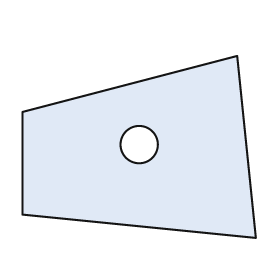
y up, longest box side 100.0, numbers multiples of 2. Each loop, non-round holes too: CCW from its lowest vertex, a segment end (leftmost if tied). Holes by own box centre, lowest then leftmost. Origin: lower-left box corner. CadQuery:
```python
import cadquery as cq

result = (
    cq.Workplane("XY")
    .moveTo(100.0, 0.0)
    .lineTo(92.0, 78.0)
    .lineTo(0.0, 54.0)
    .lineTo(0.0, 10.0)
    .close()
    .moveTo(50.0, 40.0)
    .circle(8.0)
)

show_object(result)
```